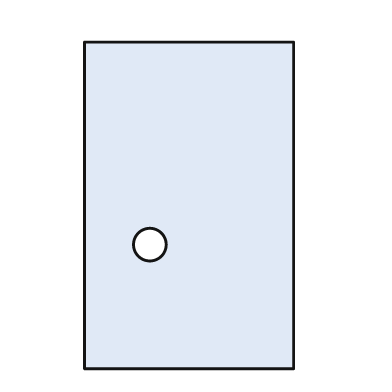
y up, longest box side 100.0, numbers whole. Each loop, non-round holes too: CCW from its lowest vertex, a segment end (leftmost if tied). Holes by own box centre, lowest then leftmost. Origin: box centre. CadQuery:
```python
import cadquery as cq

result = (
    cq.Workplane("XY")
    .moveTo(-32.0, -50.0)
    .lineTo(32.0, -50.0)
    .lineTo(32.0, 50.0)
    .lineTo(-32.0, 50.0)
    .close()
    .moveTo(-12.0, -12.0)
    .circle(5.0)
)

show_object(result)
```